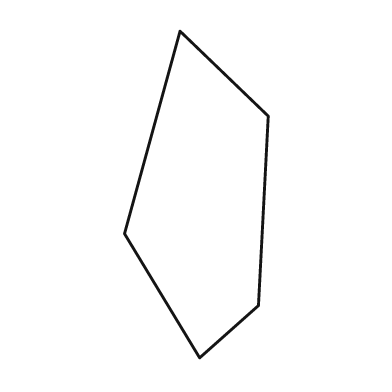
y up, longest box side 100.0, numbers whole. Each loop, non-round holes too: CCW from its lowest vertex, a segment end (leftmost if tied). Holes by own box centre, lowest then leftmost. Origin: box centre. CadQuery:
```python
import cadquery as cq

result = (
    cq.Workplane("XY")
    .moveTo(1.0, -50.0)
    .lineTo(19.0, -34.0)
    .lineTo(22.0, 24.0)
    .lineTo(-5.0, 50.0)
    .lineTo(-22.0, -12.0)
    .close()
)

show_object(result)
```